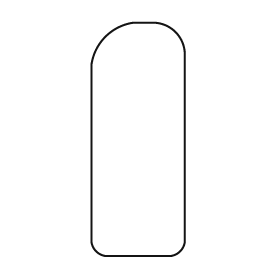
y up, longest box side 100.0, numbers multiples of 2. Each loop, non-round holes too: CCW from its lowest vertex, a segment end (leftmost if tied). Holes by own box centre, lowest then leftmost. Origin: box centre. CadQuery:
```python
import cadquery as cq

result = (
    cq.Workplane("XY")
    .moveTo(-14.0, -50.0)
    .lineTo(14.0, -50.0)
    .threePointArc((18.0, -48.0), (20.0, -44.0))
    .lineTo(20.0, 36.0)
    .threePointArc((16.0, 46.0), (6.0, 50.0))
    .lineTo(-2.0, 50.0)
    .threePointArc((-14.0, 44.0), (-20.0, 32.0))
    .lineTo(-20.0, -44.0)
    .threePointArc((-18.0, -48.0), (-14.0, -50.0))
    .close()
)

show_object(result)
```